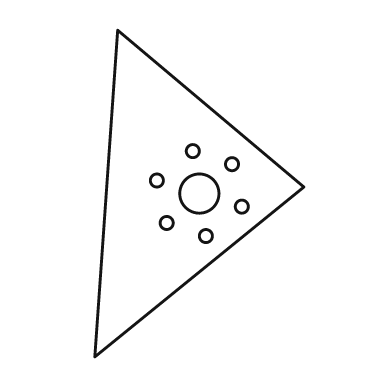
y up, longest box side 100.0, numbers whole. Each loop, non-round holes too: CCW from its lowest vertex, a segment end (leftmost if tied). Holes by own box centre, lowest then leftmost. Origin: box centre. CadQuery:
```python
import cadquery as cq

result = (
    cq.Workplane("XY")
    .moveTo(-32.0, -50.0)
    .lineTo(32.0, 2.0)
    .lineTo(-25.0, 50.0)
    .close()
    .moveTo(2.0, -13.0)
    .circle(2.0)
    .moveTo(-10.0, -9.0)
    .circle(2.0)
    .moveTo(13.0, -4.0)
    .circle(2.0)
    .moveTo(0.0, 0.0)
    .circle(6.0)
    .moveTo(-13.0, 4.0)
    .circle(2.0)
    .moveTo(10.0, 9.0)
    .circle(2.0)
    .moveTo(-2.0, 13.0)
    .circle(2.0)
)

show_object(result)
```